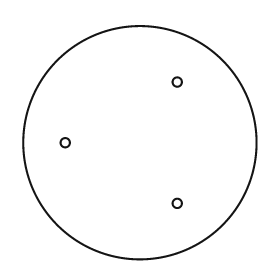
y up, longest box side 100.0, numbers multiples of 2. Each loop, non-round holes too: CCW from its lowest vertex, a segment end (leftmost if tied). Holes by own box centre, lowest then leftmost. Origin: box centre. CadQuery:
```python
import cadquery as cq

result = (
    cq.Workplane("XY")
    .moveTo(0.0, 0.0)
    .circle(50.0)
    .moveTo(16.0, -26.0)
    .circle(2.0)
    .moveTo(-32.0, 0.0)
    .circle(2.0)
    .moveTo(16.0, 26.0)
    .circle(2.0)
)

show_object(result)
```